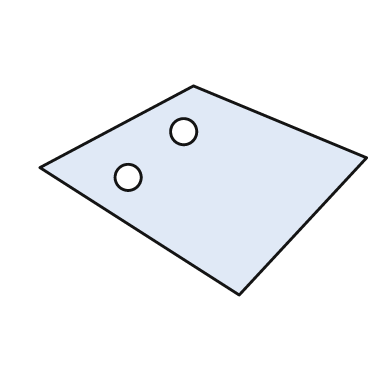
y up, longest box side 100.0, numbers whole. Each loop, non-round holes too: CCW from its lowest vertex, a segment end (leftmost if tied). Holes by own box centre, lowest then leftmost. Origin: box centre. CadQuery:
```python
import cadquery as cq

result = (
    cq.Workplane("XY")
    .moveTo(11.0, -32.0)
    .lineTo(50.0, 10.0)
    .lineTo(-3.0, 32.0)
    .lineTo(-50.0, 7.0)
    .close()
    .moveTo(-23.0, 4.0)
    .circle(4.0)
    .moveTo(-6.0, 18.0)
    .circle(4.0)
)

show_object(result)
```